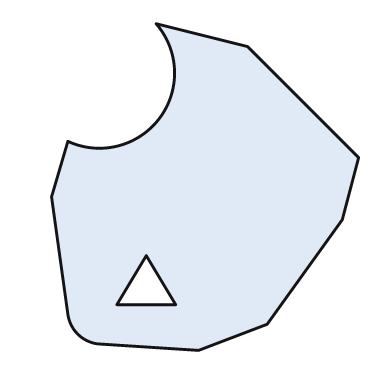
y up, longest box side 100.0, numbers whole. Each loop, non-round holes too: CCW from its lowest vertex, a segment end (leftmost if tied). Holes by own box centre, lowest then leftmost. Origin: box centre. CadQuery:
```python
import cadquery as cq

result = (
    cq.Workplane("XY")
    .moveTo(-2.0, -50.0)
    .lineTo(19.0, -42.0)
    .lineTo(42.0, -10.0)
    .lineTo(47.0, 9.0)
    .lineTo(13.0, 43.0)
    .lineTo(-15.0, 50.0)
    .threePointArc((-14.0, 21.0), (-42.0, 14.0))
    .lineTo(-47.0, -3.0)
    .lineTo(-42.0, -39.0)
    .threePointArc((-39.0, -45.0), (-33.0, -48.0))
    .close()
    .moveTo(-27.0, -36.0)
    .lineTo(-9.0, -36.0)
    .lineTo(-18.0, -21.0)
    .close()
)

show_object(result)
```